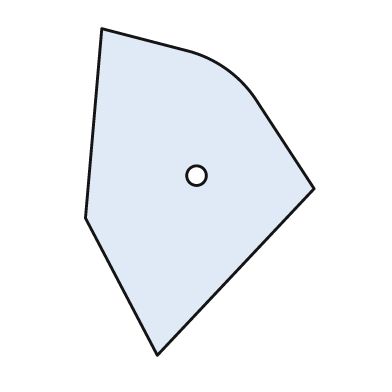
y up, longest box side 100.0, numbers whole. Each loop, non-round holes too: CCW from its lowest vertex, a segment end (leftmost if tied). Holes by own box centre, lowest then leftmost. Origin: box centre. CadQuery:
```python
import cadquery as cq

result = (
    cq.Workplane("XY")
    .moveTo(-13.0, -50.0)
    .lineTo(35.0, 1.0)
    .lineTo(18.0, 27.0)
    .threePointArc((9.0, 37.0), (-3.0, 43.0))
    .lineTo(-30.0, 50.0)
    .lineTo(-35.0, -8.0)
    .close()
    .moveTo(-1.0, 5.0)
    .circle(3.0)
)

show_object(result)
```